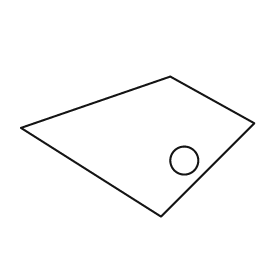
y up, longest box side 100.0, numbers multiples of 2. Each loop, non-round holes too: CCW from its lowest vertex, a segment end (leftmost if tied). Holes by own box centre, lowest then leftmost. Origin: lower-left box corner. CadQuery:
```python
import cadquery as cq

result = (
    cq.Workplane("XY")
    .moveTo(60.0, 0.0)
    .lineTo(100.0, 40.0)
    .lineTo(64.0, 60.0)
    .lineTo(0.0, 38.0)
    .close()
    .moveTo(70.0, 24.0)
    .circle(6.0)
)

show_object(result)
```